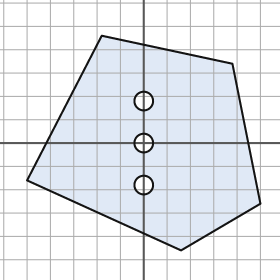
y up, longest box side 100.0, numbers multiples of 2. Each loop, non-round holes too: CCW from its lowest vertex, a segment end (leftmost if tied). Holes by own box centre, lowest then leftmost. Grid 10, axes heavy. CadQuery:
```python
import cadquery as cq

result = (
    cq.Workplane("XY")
    .moveTo(16.0, -46.0)
    .lineTo(50.0, -26.0)
    .lineTo(38.0, 34.0)
    .lineTo(-18.0, 46.0)
    .lineTo(-50.0, -16.0)
    .close()
    .moveTo(0.0, -18.0)
    .circle(4.0)
    .moveTo(0.0, 0.0)
    .circle(4.0)
    .moveTo(0.0, 18.0)
    .circle(4.0)
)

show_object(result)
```